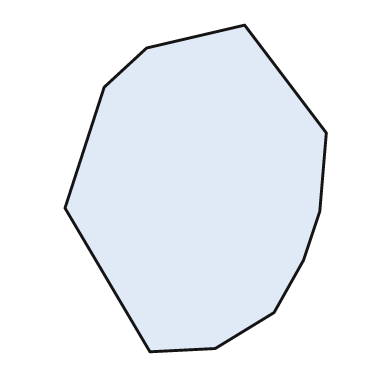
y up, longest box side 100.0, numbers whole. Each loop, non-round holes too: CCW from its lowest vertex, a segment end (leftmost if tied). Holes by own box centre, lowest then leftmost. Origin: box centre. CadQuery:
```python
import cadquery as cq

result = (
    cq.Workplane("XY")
    .moveTo(-14.0, -50.0)
    .lineTo(6.0, -49.0)
    .lineTo(24.0, -38.0)
    .lineTo(33.0, -22.0)
    .lineTo(38.0, -7.0)
    .lineTo(40.0, 17.0)
    .lineTo(15.0, 50.0)
    .lineTo(-15.0, 43.0)
    .lineTo(-28.0, 31.0)
    .lineTo(-40.0, -6.0)
    .close()
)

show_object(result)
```